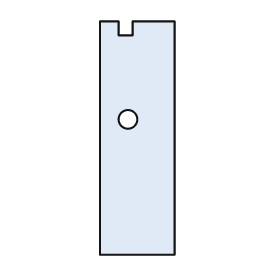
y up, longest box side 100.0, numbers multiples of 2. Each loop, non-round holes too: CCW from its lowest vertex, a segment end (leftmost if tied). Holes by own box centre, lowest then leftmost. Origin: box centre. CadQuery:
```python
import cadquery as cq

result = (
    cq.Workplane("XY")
    .moveTo(-16.0, -50.0)
    .lineTo(16.0, -50.0)
    .lineTo(16.0, 50.0)
    .lineTo(-2.0, 50.0)
    .lineTo(-2.0, 44.0)
    .lineTo(-8.0, 44.0)
    .lineTo(-8.0, 50.0)
    .lineTo(-16.0, 50.0)
    .close()
    .moveTo(-4.0, 8.0)
    .circle(4.0)
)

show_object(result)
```